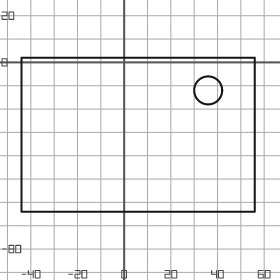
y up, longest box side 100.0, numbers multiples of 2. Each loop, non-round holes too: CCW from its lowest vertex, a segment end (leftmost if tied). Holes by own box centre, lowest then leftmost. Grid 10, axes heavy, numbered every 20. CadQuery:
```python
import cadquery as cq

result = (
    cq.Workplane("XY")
    .moveTo(-44.0, -64.0)
    .lineTo(56.0, -64.0)
    .lineTo(56.0, 2.0)
    .lineTo(-44.0, 2.0)
    .close()
    .moveTo(36.0, -12.0)
    .circle(6.0)
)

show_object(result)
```